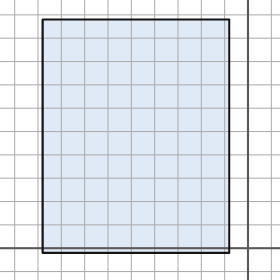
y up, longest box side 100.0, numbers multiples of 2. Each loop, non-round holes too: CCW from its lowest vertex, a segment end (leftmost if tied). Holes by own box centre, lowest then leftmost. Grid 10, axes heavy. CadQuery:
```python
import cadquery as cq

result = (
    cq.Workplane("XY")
    .moveTo(-88.0, -2.0)
    .lineTo(-8.0, -2.0)
    .lineTo(-8.0, 98.0)
    .lineTo(-88.0, 98.0)
    .close()
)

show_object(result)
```